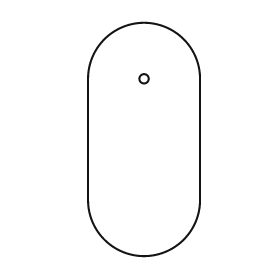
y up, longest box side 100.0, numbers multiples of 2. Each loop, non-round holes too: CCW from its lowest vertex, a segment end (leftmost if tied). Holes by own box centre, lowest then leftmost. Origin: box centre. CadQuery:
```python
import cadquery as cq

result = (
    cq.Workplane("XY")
    .moveTo(-24.0, -26.0)
    .threePointArc((0.0, -50.0), (24.0, -26.0))
    .lineTo(24.0, 26.0)
    .threePointArc((0.0, 50.0), (-24.0, 26.0))
    .close()
    .moveTo(0.0, 26.0)
    .circle(2.0)
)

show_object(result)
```